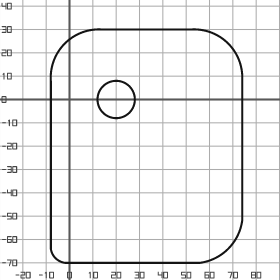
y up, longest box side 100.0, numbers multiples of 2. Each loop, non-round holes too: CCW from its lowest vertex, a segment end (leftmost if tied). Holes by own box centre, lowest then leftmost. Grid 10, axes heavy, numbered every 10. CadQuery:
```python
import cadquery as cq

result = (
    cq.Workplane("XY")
    .moveTo(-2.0, -70.0)
    .lineTo(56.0, -70.0)
    .threePointArc((68.0, -64.0), (74.0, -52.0))
    .lineTo(74.0, 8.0)
    .threePointArc((68.0, 24.0), (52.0, 30.0))
    .lineTo(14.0, 30.0)
    .threePointArc((-2.0, 24.0), (-8.0, 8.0))
    .lineTo(-8.0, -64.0)
    .threePointArc((-6.0, -68.0), (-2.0, -70.0))
    .close()
    .moveTo(20.0, 0.0)
    .circle(8.0)
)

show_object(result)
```